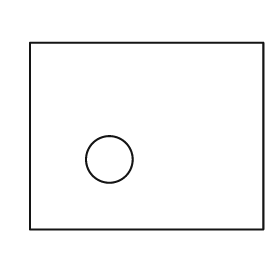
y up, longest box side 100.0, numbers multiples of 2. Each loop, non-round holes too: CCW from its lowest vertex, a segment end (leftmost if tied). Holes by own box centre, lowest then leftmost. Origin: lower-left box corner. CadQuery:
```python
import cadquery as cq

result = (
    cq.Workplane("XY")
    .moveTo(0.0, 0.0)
    .lineTo(100.0, 0.0)
    .lineTo(100.0, 80.0)
    .lineTo(0.0, 80.0)
    .close()
    .moveTo(34.0, 30.0)
    .circle(10.0)
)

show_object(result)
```